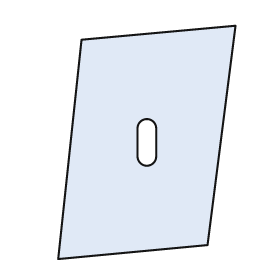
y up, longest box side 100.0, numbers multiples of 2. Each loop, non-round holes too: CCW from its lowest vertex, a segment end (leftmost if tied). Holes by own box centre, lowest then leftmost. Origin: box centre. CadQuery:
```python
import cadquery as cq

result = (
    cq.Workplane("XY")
    .moveTo(-38.0, -50.0)
    .lineTo(26.0, -44.0)
    .lineTo(38.0, 50.0)
    .lineTo(-28.0, 44.0)
    .close()
    .moveTo(-4.0, -6.0)
    .threePointArc((0.0, -10.0), (4.0, -6.0))
    .lineTo(4.0, 6.0)
    .threePointArc((0.0, 10.0), (-4.0, 6.0))
    .close()
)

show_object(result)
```